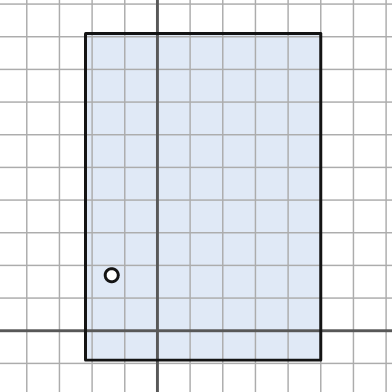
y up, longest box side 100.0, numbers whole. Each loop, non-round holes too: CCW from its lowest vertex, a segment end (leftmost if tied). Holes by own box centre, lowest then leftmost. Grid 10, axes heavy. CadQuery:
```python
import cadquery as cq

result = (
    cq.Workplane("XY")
    .moveTo(-22.0, -9.0)
    .lineTo(50.0, -9.0)
    .lineTo(50.0, 91.0)
    .lineTo(-22.0, 91.0)
    .close()
    .moveTo(-14.0, 17.0)
    .circle(2.0)
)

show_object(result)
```